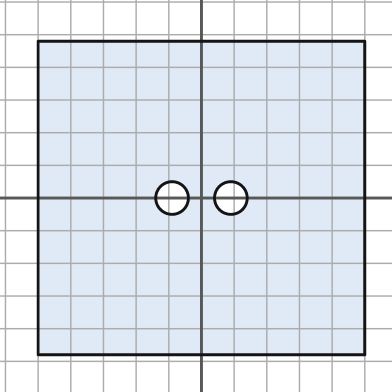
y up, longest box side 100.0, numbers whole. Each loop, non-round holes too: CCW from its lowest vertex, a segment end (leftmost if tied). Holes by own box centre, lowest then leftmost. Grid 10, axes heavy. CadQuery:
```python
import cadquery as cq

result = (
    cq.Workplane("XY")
    .moveTo(-50.0, -48.0)
    .lineTo(50.0, -48.0)
    .lineTo(50.0, 48.0)
    .lineTo(-50.0, 48.0)
    .close()
    .moveTo(-9.0, 0.0)
    .circle(5.0)
    .moveTo(9.0, 0.0)
    .circle(5.0)
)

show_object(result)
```